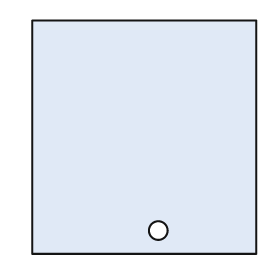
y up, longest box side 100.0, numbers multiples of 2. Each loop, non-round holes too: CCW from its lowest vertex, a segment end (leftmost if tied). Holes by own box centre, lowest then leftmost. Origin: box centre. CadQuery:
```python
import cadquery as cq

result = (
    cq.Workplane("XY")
    .moveTo(-48.0, -50.0)
    .lineTo(48.0, -50.0)
    .lineTo(48.0, 50.0)
    .lineTo(-48.0, 50.0)
    .close()
    .moveTo(6.0, -40.0)
    .circle(4.0)
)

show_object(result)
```